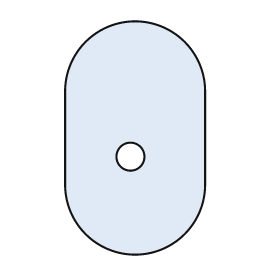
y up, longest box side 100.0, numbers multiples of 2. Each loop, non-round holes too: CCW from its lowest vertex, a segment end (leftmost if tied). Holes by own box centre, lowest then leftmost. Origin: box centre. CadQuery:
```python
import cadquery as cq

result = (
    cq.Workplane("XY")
    .moveTo(-30.0, -20.0)
    .threePointArc((0.0, -50.0), (30.0, -20.0))
    .lineTo(30.0, 20.0)
    .threePointArc((0.0, 50.0), (-30.0, 20.0))
    .close()
    .moveTo(-2.0, -8.0)
    .circle(6.0)
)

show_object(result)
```